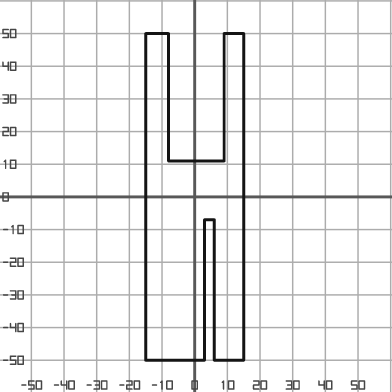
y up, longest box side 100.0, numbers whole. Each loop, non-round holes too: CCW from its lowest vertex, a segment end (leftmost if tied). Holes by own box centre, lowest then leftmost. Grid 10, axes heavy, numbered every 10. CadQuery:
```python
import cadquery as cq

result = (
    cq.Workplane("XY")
    .moveTo(-15.0, -50.0)
    .lineTo(3.0, -50.0)
    .lineTo(3.0, -7.0)
    .lineTo(6.0, -7.0)
    .lineTo(6.0, -50.0)
    .lineTo(15.0, -50.0)
    .lineTo(15.0, 50.0)
    .lineTo(9.0, 50.0)
    .lineTo(9.0, 11.0)
    .lineTo(-8.0, 11.0)
    .lineTo(-8.0, 50.0)
    .lineTo(-15.0, 50.0)
    .close()
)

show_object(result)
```